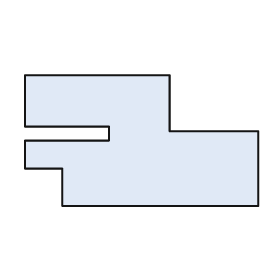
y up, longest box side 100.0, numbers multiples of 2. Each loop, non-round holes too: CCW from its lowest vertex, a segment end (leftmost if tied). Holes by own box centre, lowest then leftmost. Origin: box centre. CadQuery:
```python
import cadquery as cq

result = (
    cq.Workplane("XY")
    .moveTo(-34.0, -28.0)
    .lineTo(50.0, -28.0)
    .lineTo(50.0, 4.0)
    .lineTo(12.0, 4.0)
    .lineTo(12.0, 28.0)
    .lineTo(-50.0, 28.0)
    .lineTo(-50.0, 6.0)
    .lineTo(-14.0, 6.0)
    .lineTo(-14.0, 0.0)
    .lineTo(-50.0, 0.0)
    .lineTo(-50.0, -12.0)
    .lineTo(-34.0, -12.0)
    .close()
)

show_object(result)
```